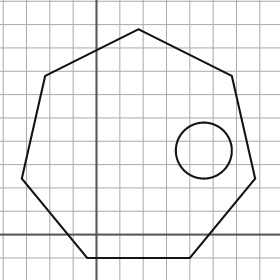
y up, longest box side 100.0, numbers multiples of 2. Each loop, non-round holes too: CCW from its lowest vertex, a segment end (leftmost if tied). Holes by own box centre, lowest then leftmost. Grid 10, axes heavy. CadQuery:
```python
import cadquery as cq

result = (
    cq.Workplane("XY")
    .moveTo(-4.0, -10.0)
    .lineTo(40.0, -10.0)
    .lineTo(68.0, 24.0)
    .lineTo(58.0, 68.0)
    .lineTo(18.0, 88.0)
    .lineTo(-22.0, 68.0)
    .lineTo(-32.0, 24.0)
    .close()
    .moveTo(46.0, 36.0)
    .circle(12.0)
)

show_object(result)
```